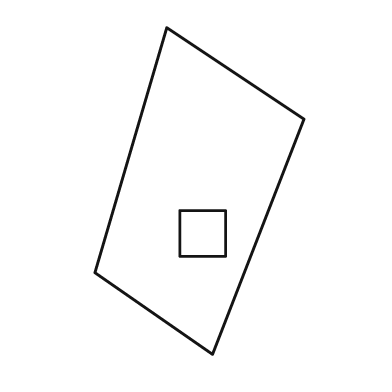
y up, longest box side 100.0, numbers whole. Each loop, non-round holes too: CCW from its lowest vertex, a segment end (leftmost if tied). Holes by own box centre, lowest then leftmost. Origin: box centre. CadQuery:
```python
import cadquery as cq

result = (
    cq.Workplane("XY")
    .moveTo(4.0, -50.0)
    .lineTo(32.0, 22.0)
    .lineTo(-10.0, 50.0)
    .lineTo(-32.0, -25.0)
    .close()
    .moveTo(-6.0, -20.0)
    .lineTo(8.0, -20.0)
    .lineTo(8.0, -6.0)
    .lineTo(-6.0, -6.0)
    .close()
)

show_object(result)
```